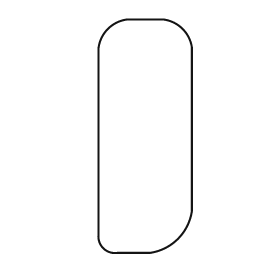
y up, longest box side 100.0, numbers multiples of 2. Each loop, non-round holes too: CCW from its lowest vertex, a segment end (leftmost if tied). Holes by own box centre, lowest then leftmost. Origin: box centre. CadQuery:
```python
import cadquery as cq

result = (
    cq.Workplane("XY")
    .moveTo(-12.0, -50.0)
    .lineTo(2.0, -50.0)
    .threePointArc((14.0, -44.0), (20.0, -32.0))
    .lineTo(20.0, 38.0)
    .threePointArc((16.0, 46.0), (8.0, 50.0))
    .lineTo(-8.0, 50.0)
    .threePointArc((-16.0, 46.0), (-20.0, 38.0))
    .lineTo(-20.0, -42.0)
    .threePointArc((-18.0, -48.0), (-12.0, -50.0))
    .close()
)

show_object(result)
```